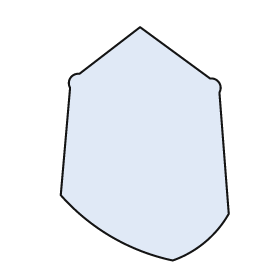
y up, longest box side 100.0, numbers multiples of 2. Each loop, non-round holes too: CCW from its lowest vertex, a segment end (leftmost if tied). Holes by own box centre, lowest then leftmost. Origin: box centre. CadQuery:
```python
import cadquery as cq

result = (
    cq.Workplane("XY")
    .moveTo(12.0, -50.0)
    .threePointArc((26.0, -42.0), (36.0, -30.0))
    .lineTo(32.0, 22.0)
    .threePointArc((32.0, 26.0), (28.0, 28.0))
    .lineTo(-2.0, 50.0)
    .lineTo(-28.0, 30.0)
    .threePointArc((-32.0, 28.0), (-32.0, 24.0))
    .lineTo(-36.0, -22.0)
    .threePointArc((-14.0, -40.0), (12.0, -50.0))
    .close()
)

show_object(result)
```